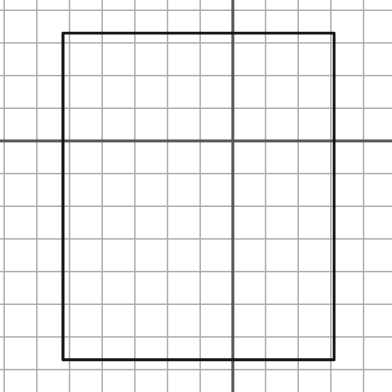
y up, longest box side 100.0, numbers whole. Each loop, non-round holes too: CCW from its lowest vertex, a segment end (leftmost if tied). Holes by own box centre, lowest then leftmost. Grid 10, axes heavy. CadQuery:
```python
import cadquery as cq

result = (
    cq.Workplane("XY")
    .moveTo(-52.0, -67.0)
    .lineTo(31.0, -67.0)
    .lineTo(31.0, 33.0)
    .lineTo(-52.0, 33.0)
    .close()
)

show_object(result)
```